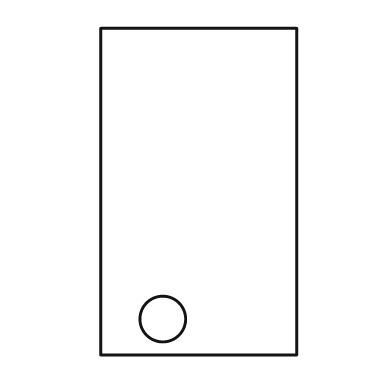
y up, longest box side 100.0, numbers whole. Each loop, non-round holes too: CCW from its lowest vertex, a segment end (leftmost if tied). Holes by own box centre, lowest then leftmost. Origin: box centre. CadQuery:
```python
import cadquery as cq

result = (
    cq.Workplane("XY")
    .moveTo(-30.0, -50.0)
    .lineTo(30.0, -50.0)
    .lineTo(30.0, 50.0)
    .lineTo(-30.0, 50.0)
    .close()
    .moveTo(-11.0, -39.0)
    .circle(7.0)
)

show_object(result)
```